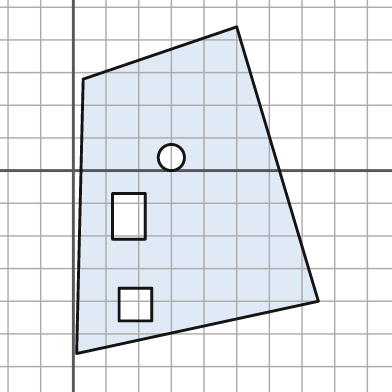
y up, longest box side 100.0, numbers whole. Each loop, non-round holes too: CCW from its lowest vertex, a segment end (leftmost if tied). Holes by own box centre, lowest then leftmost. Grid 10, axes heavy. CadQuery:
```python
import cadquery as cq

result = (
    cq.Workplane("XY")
    .moveTo(1.0, -56.0)
    .lineTo(75.0, -40.0)
    .lineTo(50.0, 44.0)
    .lineTo(3.0, 28.0)
    .close()
    .moveTo(14.0, -46.0)
    .lineTo(24.0, -46.0)
    .lineTo(24.0, -36.0)
    .lineTo(14.0, -36.0)
    .close()
    .moveTo(12.0, -21.0)
    .lineTo(22.0, -21.0)
    .lineTo(22.0, -7.0)
    .lineTo(12.0, -7.0)
    .close()
    .moveTo(30.0, 4.0)
    .circle(4.0)
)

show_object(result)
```